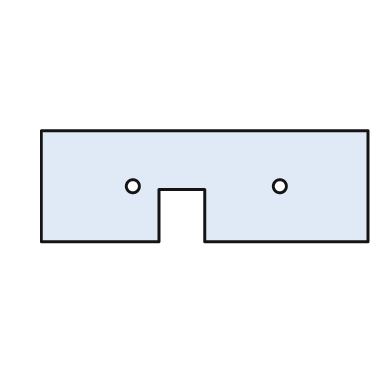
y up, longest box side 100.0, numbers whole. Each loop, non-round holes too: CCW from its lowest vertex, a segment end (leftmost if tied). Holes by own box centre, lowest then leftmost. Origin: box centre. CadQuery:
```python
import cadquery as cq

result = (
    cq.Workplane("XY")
    .moveTo(-50.0, -17.0)
    .lineTo(-14.0, -17.0)
    .lineTo(-14.0, -1.0)
    .lineTo(0.0, -1.0)
    .lineTo(0.0, -17.0)
    .lineTo(50.0, -17.0)
    .lineTo(50.0, 17.0)
    .lineTo(-50.0, 17.0)
    .close()
    .moveTo(-22.0, 0.0)
    .circle(2.0)
    .moveTo(23.0, 0.0)
    .circle(2.0)
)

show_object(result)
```